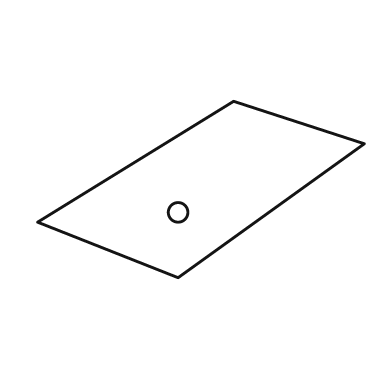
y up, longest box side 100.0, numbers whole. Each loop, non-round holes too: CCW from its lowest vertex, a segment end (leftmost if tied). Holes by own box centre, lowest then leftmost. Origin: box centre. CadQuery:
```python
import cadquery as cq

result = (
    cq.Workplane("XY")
    .moveTo(-7.0, -27.0)
    .lineTo(50.0, 14.0)
    .lineTo(10.0, 27.0)
    .lineTo(-50.0, -10.0)
    .close()
    .moveTo(-7.0, -7.0)
    .circle(3.0)
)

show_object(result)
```